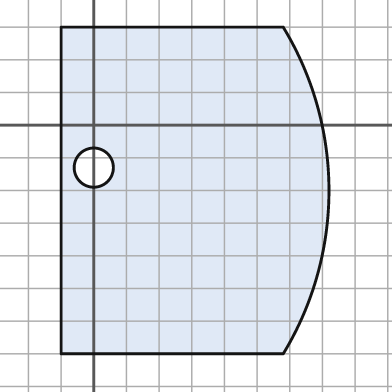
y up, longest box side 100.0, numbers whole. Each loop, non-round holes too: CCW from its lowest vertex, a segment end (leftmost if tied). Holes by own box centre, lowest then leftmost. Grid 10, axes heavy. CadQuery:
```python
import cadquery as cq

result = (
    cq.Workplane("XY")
    .moveTo(-10.0, -70.0)
    .lineTo(58.0, -70.0)
    .threePointArc((72.0, -20.0), (58.0, 30.0))
    .lineTo(-10.0, 30.0)
    .close()
    .moveTo(0.0, -13.0)
    .circle(6.0)
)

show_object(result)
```